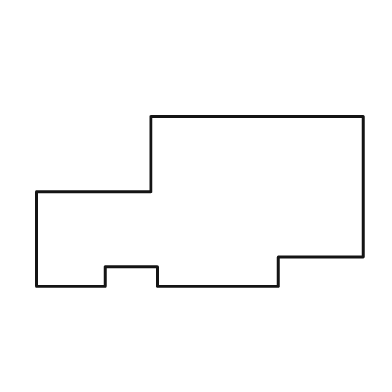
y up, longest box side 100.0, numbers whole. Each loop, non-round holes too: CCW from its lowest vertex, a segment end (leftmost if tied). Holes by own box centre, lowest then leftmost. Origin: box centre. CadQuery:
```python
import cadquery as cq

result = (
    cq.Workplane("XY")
    .moveTo(-50.0, -26.0)
    .lineTo(-29.0, -26.0)
    .lineTo(-29.0, -20.0)
    .lineTo(-13.0, -20.0)
    .lineTo(-13.0, -26.0)
    .lineTo(24.0, -26.0)
    .lineTo(24.0, -17.0)
    .lineTo(50.0, -17.0)
    .lineTo(50.0, 26.0)
    .lineTo(-15.0, 26.0)
    .lineTo(-15.0, 3.0)
    .lineTo(-50.0, 3.0)
    .close()
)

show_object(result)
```